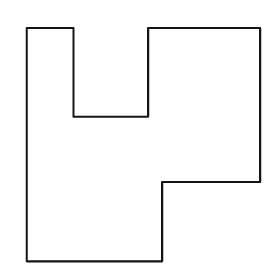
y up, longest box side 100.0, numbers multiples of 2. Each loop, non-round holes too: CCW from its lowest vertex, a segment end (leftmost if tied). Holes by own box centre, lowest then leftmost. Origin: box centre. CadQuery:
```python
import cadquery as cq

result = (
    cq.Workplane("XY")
    .moveTo(-50.0, -50.0)
    .lineTo(8.0, -50.0)
    .lineTo(8.0, -16.0)
    .lineTo(50.0, -16.0)
    .lineTo(50.0, 50.0)
    .lineTo(2.0, 50.0)
    .lineTo(2.0, 12.0)
    .lineTo(-30.0, 12.0)
    .lineTo(-30.0, 50.0)
    .lineTo(-50.0, 50.0)
    .close()
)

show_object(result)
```